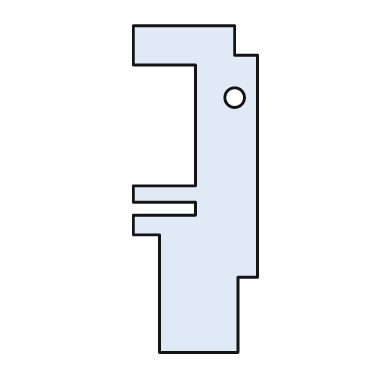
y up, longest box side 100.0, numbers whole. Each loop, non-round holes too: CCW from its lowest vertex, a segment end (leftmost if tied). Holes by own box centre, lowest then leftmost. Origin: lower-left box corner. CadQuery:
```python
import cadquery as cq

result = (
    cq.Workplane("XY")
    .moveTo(8.0, 0.0)
    .lineTo(32.0, 0.0)
    .lineTo(32.0, 23.0)
    .lineTo(38.0, 23.0)
    .lineTo(38.0, 91.0)
    .lineTo(31.0, 91.0)
    .lineTo(31.0, 100.0)
    .lineTo(0.0, 100.0)
    .lineTo(0.0, 88.0)
    .lineTo(19.0, 88.0)
    .lineTo(19.0, 51.0)
    .lineTo(0.0, 51.0)
    .lineTo(0.0, 46.0)
    .lineTo(19.0, 46.0)
    .lineTo(19.0, 42.0)
    .lineTo(0.0, 42.0)
    .lineTo(0.0, 36.0)
    .lineTo(8.0, 36.0)
    .close()
    .moveTo(31.0, 78.0)
    .circle(3.0)
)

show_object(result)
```